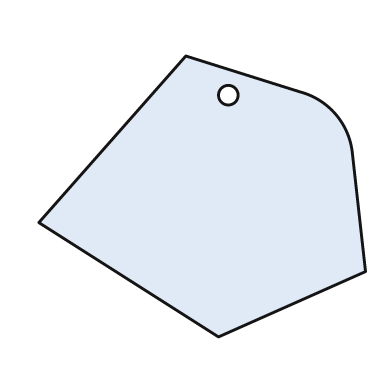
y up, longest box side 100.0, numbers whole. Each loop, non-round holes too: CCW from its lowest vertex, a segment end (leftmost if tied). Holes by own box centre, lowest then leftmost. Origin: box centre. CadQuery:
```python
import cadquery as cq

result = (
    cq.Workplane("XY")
    .moveTo(5.0, -43.0)
    .lineTo(50.0, -23.0)
    .lineTo(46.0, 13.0)
    .threePointArc((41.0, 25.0), (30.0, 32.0))
    .lineTo(-5.0, 43.0)
    .lineTo(-50.0, -8.0)
    .close()
    .moveTo(8.0, 31.0)
    .circle(3.0)
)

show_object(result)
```